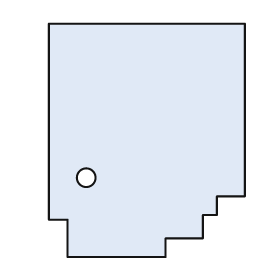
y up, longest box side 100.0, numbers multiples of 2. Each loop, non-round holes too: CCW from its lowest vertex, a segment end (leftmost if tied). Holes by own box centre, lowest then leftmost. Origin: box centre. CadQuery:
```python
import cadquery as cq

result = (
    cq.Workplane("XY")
    .moveTo(-34.0, -50.0)
    .lineTo(8.0, -50.0)
    .lineTo(8.0, -42.0)
    .lineTo(24.0, -42.0)
    .lineTo(24.0, -32.0)
    .lineTo(30.0, -32.0)
    .lineTo(30.0, -24.0)
    .lineTo(42.0, -24.0)
    .lineTo(42.0, 50.0)
    .lineTo(-42.0, 50.0)
    .lineTo(-42.0, -34.0)
    .lineTo(-34.0, -34.0)
    .close()
    .moveTo(-26.0, -16.0)
    .circle(4.0)
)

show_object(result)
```